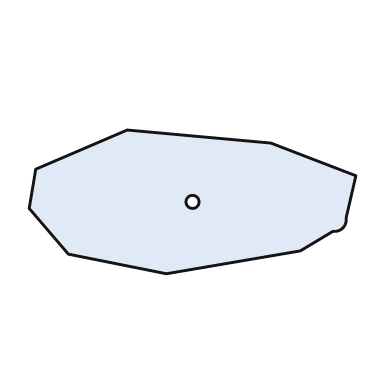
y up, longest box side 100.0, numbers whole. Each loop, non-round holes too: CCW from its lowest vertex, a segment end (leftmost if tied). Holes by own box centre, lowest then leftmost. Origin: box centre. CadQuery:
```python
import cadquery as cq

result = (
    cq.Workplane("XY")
    .moveTo(-8.0, -22.0)
    .lineTo(33.0, -15.0)
    .lineTo(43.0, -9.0)
    .threePointArc((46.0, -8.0), (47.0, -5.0))
    .lineTo(50.0, 8.0)
    .lineTo(24.0, 18.0)
    .lineTo(-20.0, 22.0)
    .lineTo(-48.0, 10.0)
    .lineTo(-50.0, -2.0)
    .lineTo(-38.0, -16.0)
    .close()
    .moveTo(0.0, 0.0)
    .circle(2.0)
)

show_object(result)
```